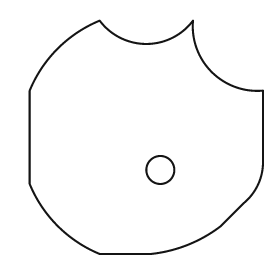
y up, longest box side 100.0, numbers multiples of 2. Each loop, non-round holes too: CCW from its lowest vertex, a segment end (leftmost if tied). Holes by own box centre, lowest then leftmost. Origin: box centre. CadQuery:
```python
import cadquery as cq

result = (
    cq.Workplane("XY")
    .moveTo(-20.0, -50.0)
    .lineTo(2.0, -50.0)
    .threePointArc((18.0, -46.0), (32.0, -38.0))
    .lineTo(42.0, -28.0)
    .threePointArc((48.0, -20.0), (50.0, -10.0))
    .lineTo(50.0, 20.0)
    .threePointArc((28.0, 28.0), (20.0, 50.0))
    .threePointArc((0.0, 40.0), (-20.0, 50.0))
    .threePointArc((-38.0, 38.0), (-50.0, 20.0))
    .lineTo(-50.0, -20.0)
    .threePointArc((-38.0, -38.0), (-20.0, -50.0))
    .close()
    .moveTo(6.0, -14.0)
    .circle(6.0)
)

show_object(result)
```